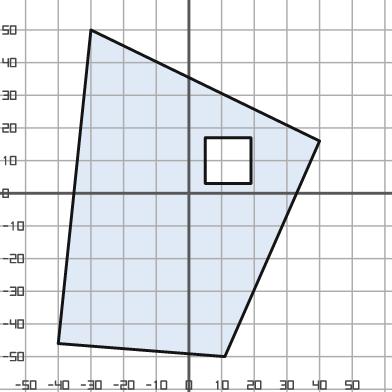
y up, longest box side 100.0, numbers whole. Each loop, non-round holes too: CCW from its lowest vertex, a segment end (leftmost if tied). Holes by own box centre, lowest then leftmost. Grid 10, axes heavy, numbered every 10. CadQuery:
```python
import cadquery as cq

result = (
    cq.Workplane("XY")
    .moveTo(11.0, -50.0)
    .lineTo(40.0, 16.0)
    .lineTo(-30.0, 50.0)
    .lineTo(-40.0, -46.0)
    .close()
    .moveTo(5.0, 3.0)
    .lineTo(19.0, 3.0)
    .lineTo(19.0, 17.0)
    .lineTo(5.0, 17.0)
    .close()
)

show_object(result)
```